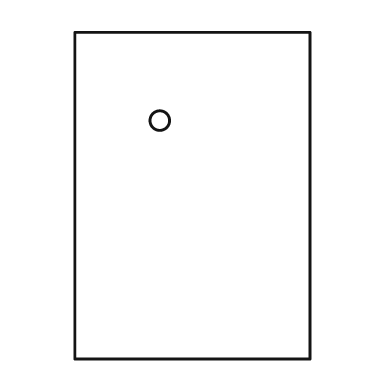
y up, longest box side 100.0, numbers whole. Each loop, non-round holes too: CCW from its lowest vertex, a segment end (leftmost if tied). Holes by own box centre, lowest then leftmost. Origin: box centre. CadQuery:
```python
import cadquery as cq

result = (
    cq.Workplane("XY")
    .moveTo(-36.0, -50.0)
    .lineTo(36.0, -50.0)
    .lineTo(36.0, 50.0)
    .lineTo(-36.0, 50.0)
    .close()
    .moveTo(-10.0, 23.0)
    .circle(3.0)
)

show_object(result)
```